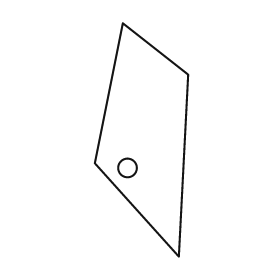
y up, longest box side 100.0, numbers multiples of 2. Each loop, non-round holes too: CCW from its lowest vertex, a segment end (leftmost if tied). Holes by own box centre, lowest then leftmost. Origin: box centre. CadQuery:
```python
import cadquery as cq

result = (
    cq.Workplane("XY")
    .moveTo(16.0, -50.0)
    .lineTo(20.0, 28.0)
    .lineTo(-8.0, 50.0)
    .lineTo(-20.0, -10.0)
    .close()
    .moveTo(-6.0, -12.0)
    .circle(4.0)
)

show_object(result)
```